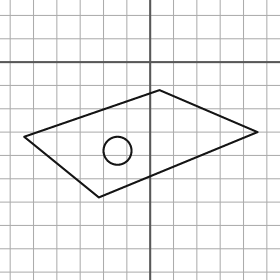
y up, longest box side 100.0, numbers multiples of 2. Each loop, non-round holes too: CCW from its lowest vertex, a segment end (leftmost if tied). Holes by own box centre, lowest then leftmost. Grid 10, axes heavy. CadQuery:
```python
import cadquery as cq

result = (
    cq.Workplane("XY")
    .moveTo(-22.0, -58.0)
    .lineTo(46.0, -30.0)
    .lineTo(4.0, -12.0)
    .lineTo(-54.0, -32.0)
    .close()
    .moveTo(-14.0, -38.0)
    .circle(6.0)
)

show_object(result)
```